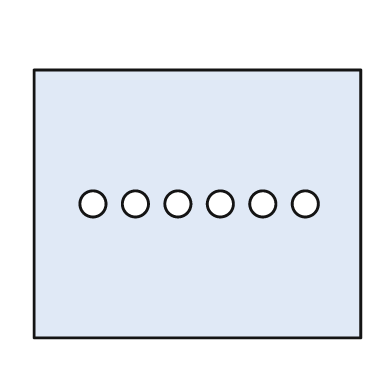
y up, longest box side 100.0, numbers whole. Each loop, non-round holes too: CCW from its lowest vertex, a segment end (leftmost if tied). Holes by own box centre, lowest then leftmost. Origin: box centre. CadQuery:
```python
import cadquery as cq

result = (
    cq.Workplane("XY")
    .moveTo(-50.0, -41.0)
    .lineTo(50.0, -41.0)
    .lineTo(50.0, 41.0)
    .lineTo(-50.0, 41.0)
    .close()
    .moveTo(-32.0, 0.0)
    .circle(4.0)
    .moveTo(-19.0, 0.0)
    .circle(4.0)
    .moveTo(-6.0, 0.0)
    .circle(4.0)
    .moveTo(7.0, 0.0)
    .circle(4.0)
    .moveTo(20.0, 0.0)
    .circle(4.0)
    .moveTo(33.0, 0.0)
    .circle(4.0)
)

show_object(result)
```